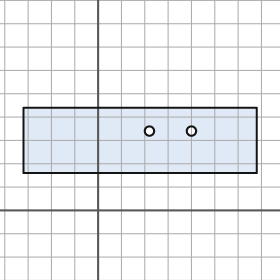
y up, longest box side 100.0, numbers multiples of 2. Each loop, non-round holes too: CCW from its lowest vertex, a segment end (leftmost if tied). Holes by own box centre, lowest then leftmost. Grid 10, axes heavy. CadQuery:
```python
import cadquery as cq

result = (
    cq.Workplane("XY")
    .moveTo(-32.0, 16.0)
    .lineTo(68.0, 16.0)
    .lineTo(68.0, 44.0)
    .lineTo(-32.0, 44.0)
    .close()
    .moveTo(22.0, 34.0)
    .circle(2.0)
    .moveTo(40.0, 34.0)
    .circle(2.0)
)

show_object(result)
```